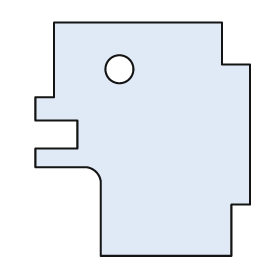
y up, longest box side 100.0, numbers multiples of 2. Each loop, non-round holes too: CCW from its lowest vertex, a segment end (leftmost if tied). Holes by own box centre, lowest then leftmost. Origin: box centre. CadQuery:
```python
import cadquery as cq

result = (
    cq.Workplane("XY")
    .moveTo(-18.0, -50.0)
    .lineTo(38.0, -50.0)
    .lineTo(38.0, -28.0)
    .lineTo(46.0, -28.0)
    .lineTo(46.0, 32.0)
    .lineTo(34.0, 32.0)
    .lineTo(34.0, 50.0)
    .lineTo(-38.0, 50.0)
    .lineTo(-38.0, 18.0)
    .lineTo(-46.0, 18.0)
    .lineTo(-46.0, 8.0)
    .lineTo(-28.0, 8.0)
    .lineTo(-28.0, -4.0)
    .lineTo(-46.0, -4.0)
    .lineTo(-46.0, -12.0)
    .lineTo(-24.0, -12.0)
    .threePointArc((-20.0, -14.0), (-18.0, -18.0))
    .close()
    .moveTo(-10.0, 30.0)
    .circle(6.0)
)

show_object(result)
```